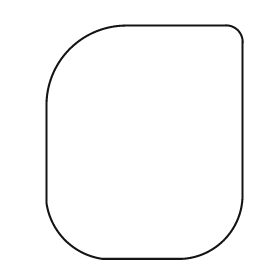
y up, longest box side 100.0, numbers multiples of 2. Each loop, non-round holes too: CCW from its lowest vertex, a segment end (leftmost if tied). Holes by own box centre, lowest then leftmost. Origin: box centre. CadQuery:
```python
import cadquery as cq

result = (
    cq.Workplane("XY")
    .moveTo(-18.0, -50.0)
    .lineTo(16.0, -50.0)
    .threePointArc((34.0, -42.0), (42.0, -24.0))
    .lineTo(42.0, 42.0)
    .threePointArc((40.0, 48.0), (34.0, 50.0))
    .lineTo(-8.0, 50.0)
    .threePointArc((-32.0, 40.0), (-42.0, 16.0))
    .lineTo(-42.0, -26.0)
    .threePointArc((-34.0, -42.0), (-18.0, -50.0))
    .close()
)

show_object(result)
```